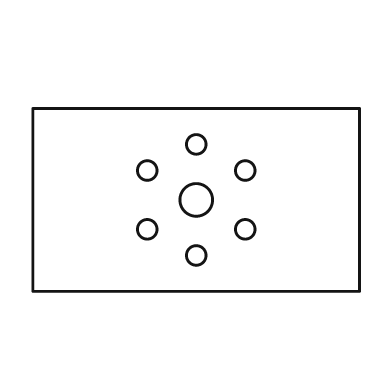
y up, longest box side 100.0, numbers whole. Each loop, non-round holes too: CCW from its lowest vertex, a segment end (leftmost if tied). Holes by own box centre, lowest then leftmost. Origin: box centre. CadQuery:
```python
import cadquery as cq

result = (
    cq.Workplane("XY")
    .moveTo(-50.0, -28.0)
    .lineTo(50.0, -28.0)
    .lineTo(50.0, 28.0)
    .lineTo(-50.0, 28.0)
    .close()
    .moveTo(0.0, -17.0)
    .circle(3.0)
    .moveTo(-15.0, -9.0)
    .circle(3.0)
    .moveTo(15.0, -9.0)
    .circle(3.0)
    .moveTo(0.0, 0.0)
    .circle(5.0)
    .moveTo(-15.0, 9.0)
    .circle(3.0)
    .moveTo(15.0, 9.0)
    .circle(3.0)
    .moveTo(0.0, 17.0)
    .circle(3.0)
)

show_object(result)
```